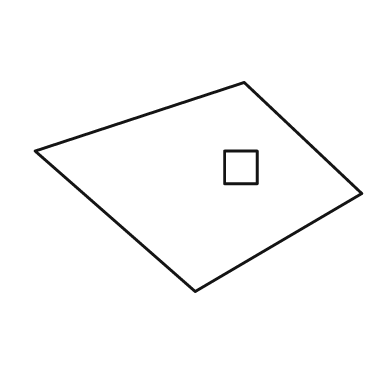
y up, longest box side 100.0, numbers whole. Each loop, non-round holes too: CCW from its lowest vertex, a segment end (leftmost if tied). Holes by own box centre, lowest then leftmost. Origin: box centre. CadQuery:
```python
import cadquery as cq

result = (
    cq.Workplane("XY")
    .moveTo(-1.0, -32.0)
    .lineTo(50.0, -2.0)
    .lineTo(14.0, 32.0)
    .lineTo(-50.0, 11.0)
    .close()
    .moveTo(8.0, 1.0)
    .lineTo(18.0, 1.0)
    .lineTo(18.0, 11.0)
    .lineTo(8.0, 11.0)
    .close()
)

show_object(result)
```